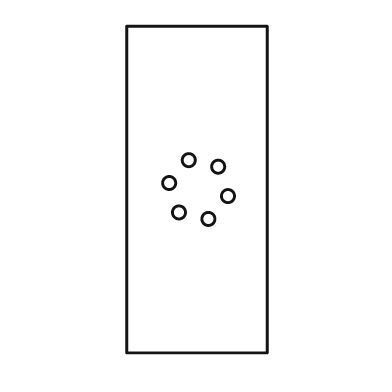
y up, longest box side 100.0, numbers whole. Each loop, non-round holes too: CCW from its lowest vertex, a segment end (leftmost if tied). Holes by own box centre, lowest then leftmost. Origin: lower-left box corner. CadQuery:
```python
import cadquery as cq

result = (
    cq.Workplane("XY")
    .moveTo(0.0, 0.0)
    .lineTo(43.0, 0.0)
    .lineTo(43.0, 100.0)
    .lineTo(0.0, 100.0)
    .close()
    .moveTo(25.0, 41.0)
    .circle(2.0)
    .moveTo(16.0, 43.0)
    .circle(2.0)
    .moveTo(31.0, 48.0)
    .circle(2.0)
    .moveTo(13.0, 52.0)
    .circle(2.0)
    .moveTo(28.0, 57.0)
    .circle(2.0)
    .moveTo(19.0, 59.0)
    .circle(2.0)
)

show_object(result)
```